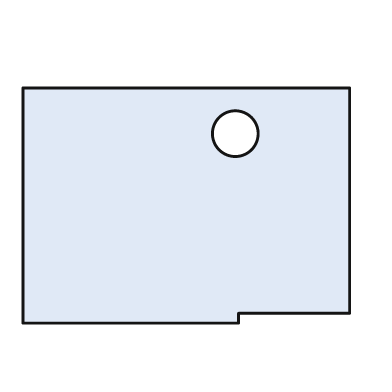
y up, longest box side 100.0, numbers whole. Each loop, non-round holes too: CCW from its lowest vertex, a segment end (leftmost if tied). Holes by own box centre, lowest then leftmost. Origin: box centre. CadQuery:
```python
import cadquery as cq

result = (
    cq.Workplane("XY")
    .moveTo(-50.0, -36.0)
    .lineTo(16.0, -36.0)
    .lineTo(16.0, -33.0)
    .lineTo(50.0, -33.0)
    .lineTo(50.0, 36.0)
    .lineTo(-50.0, 36.0)
    .close()
    .moveTo(15.0, 22.0)
    .circle(7.0)
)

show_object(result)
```